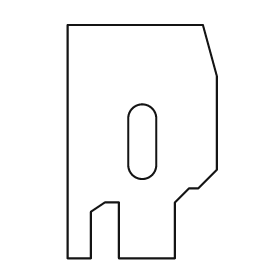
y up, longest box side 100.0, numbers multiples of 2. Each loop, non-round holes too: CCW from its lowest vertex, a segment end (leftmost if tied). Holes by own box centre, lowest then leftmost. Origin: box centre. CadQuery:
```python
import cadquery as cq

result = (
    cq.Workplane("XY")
    .moveTo(-32.0, -50.0)
    .lineTo(-22.0, -50.0)
    .lineTo(-22.0, -30.0)
    .lineTo(-16.0, -26.0)
    .lineTo(-10.0, -26.0)
    .lineTo(-10.0, -50.0)
    .lineTo(14.0, -50.0)
    .lineTo(14.0, -26.0)
    .lineTo(20.0, -20.0)
    .lineTo(24.0, -20.0)
    .lineTo(32.0, -12.0)
    .lineTo(32.0, 28.0)
    .lineTo(26.0, 50.0)
    .lineTo(-32.0, 50.0)
    .close()
    .moveTo(-6.0, -10.0)
    .threePointArc((0.0, -16.0), (6.0, -10.0))
    .lineTo(6.0, 10.0)
    .threePointArc((0.0, 16.0), (-6.0, 10.0))
    .close()
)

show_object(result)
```